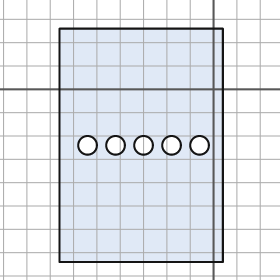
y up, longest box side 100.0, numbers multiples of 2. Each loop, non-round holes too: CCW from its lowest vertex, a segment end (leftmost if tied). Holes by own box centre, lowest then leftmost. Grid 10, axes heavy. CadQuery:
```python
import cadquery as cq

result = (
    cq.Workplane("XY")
    .moveTo(-66.0, -74.0)
    .lineTo(4.0, -74.0)
    .lineTo(4.0, 26.0)
    .lineTo(-66.0, 26.0)
    .close()
    .moveTo(-54.0, -24.0)
    .circle(4.0)
    .moveTo(-42.0, -24.0)
    .circle(4.0)
    .moveTo(-30.0, -24.0)
    .circle(4.0)
    .moveTo(-18.0, -24.0)
    .circle(4.0)
    .moveTo(-6.0, -24.0)
    .circle(4.0)
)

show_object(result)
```